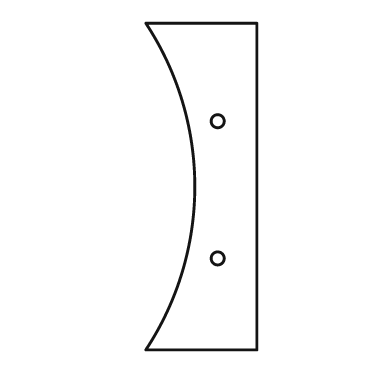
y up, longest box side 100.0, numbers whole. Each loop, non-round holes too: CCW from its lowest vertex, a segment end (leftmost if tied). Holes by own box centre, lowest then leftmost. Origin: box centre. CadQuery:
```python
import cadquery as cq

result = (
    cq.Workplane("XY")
    .moveTo(-17.0, -50.0)
    .lineTo(17.0, -50.0)
    .lineTo(17.0, 50.0)
    .lineTo(-17.0, 50.0)
    .threePointArc((-2.0, 0.0), (-17.0, -50.0))
    .close()
    .moveTo(5.0, -22.0)
    .circle(2.0)
    .moveTo(5.0, 20.0)
    .circle(2.0)
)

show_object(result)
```